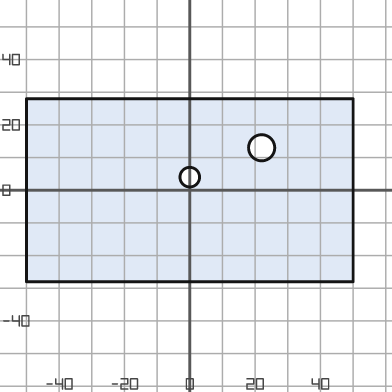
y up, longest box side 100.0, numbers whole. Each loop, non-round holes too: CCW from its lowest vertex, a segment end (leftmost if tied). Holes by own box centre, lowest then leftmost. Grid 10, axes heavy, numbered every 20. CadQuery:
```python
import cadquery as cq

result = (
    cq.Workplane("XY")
    .moveTo(-50.0, -28.0)
    .lineTo(50.0, -28.0)
    .lineTo(50.0, 28.0)
    .lineTo(-50.0, 28.0)
    .close()
    .moveTo(0.0, 4.0)
    .circle(3.0)
    .moveTo(22.0, 13.0)
    .circle(4.0)
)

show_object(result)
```